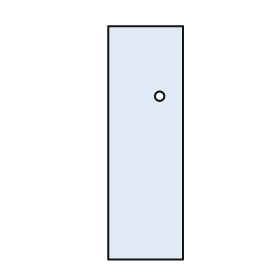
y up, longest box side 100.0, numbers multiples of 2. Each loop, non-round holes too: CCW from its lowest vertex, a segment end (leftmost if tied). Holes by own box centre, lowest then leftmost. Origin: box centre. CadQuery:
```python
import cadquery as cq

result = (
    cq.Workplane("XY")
    .moveTo(-16.0, -50.0)
    .lineTo(16.0, -50.0)
    .lineTo(16.0, 50.0)
    .lineTo(-16.0, 50.0)
    .close()
    .moveTo(6.0, 20.0)
    .circle(2.0)
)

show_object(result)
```